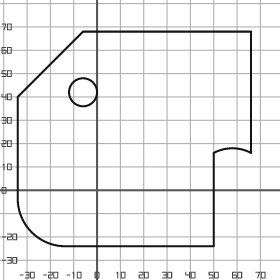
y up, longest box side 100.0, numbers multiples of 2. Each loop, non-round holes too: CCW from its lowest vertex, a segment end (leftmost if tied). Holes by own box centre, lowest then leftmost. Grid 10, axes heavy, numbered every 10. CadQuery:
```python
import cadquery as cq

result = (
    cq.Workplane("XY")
    .moveTo(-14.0, -24.0)
    .lineTo(50.0, -24.0)
    .lineTo(50.0, 16.0)
    .threePointArc((58.0, 18.0), (66.0, 16.0))
    .lineTo(66.0, 68.0)
    .lineTo(-6.0, 68.0)
    .lineTo(-34.0, 40.0)
    .lineTo(-34.0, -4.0)
    .threePointArc((-28.0, -18.0), (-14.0, -24.0))
    .close()
    .moveTo(-6.0, 42.0)
    .circle(6.0)
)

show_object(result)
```